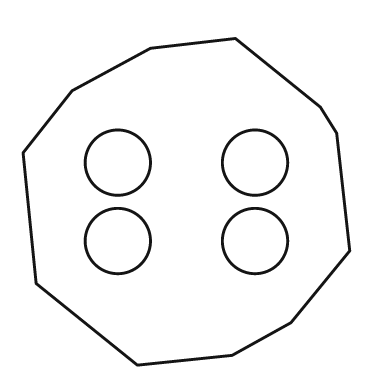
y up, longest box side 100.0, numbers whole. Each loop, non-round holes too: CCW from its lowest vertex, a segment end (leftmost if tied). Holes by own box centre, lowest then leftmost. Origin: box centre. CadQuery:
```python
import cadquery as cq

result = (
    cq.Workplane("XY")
    .moveTo(-15.0, -50.0)
    .lineTo(14.0, -47.0)
    .lineTo(32.0, -37.0)
    .lineTo(50.0, -15.0)
    .lineTo(46.0, 21.0)
    .lineTo(41.0, 29.0)
    .lineTo(15.0, 50.0)
    .lineTo(-11.0, 47.0)
    .lineTo(-35.0, 34.0)
    .lineTo(-50.0, 15.0)
    .lineTo(-46.0, -25.0)
    .close()
    .moveTo(-21.0, -12.0)
    .circle(10.0)
    .moveTo(21.0, -12.0)
    .circle(10.0)
    .moveTo(-21.0, 12.0)
    .circle(10.0)
    .moveTo(21.0, 12.0)
    .circle(10.0)
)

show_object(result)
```